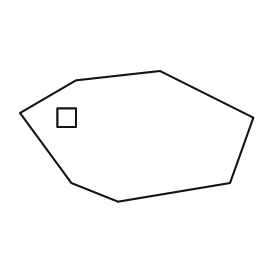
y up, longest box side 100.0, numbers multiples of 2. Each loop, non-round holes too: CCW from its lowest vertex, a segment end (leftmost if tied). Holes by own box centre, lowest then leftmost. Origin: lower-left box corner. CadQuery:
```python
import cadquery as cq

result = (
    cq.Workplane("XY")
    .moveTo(42.0, 0.0)
    .lineTo(90.0, 8.0)
    .lineTo(100.0, 36.0)
    .lineTo(60.0, 56.0)
    .lineTo(24.0, 52.0)
    .lineTo(0.0, 38.0)
    .lineTo(22.0, 8.0)
    .close()
    .moveTo(16.0, 32.0)
    .lineTo(24.0, 32.0)
    .lineTo(24.0, 40.0)
    .lineTo(16.0, 40.0)
    .close()
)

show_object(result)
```